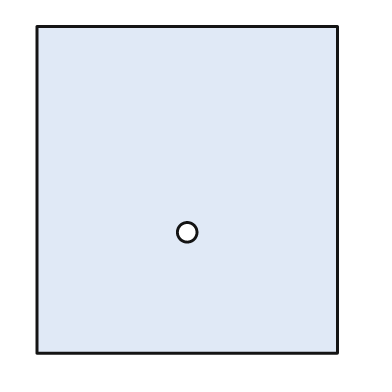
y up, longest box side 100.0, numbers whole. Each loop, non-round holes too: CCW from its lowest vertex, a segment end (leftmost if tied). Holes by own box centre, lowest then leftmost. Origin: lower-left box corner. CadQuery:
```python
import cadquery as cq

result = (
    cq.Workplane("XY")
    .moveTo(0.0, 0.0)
    .lineTo(92.0, 0.0)
    .lineTo(92.0, 100.0)
    .lineTo(0.0, 100.0)
    .close()
    .moveTo(46.0, 37.0)
    .circle(3.0)
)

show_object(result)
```